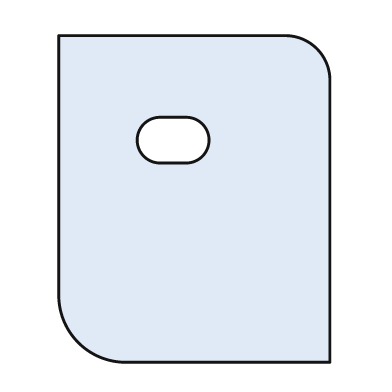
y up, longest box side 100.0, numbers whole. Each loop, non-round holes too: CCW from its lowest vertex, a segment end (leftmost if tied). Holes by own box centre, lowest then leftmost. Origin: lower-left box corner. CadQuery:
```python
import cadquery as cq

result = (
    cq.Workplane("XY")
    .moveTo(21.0, 0.0)
    .lineTo(83.0, 0.0)
    .lineTo(83.0, 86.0)
    .threePointArc((79.0, 96.0), (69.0, 100.0))
    .lineTo(0.0, 100.0)
    .lineTo(0.0, 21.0)
    .threePointArc((6.0, 6.0), (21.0, 0.0))
    .close()
    .moveTo(31.0, 61.0)
    .lineTo(39.0, 61.0)
    .threePointArc((46.0, 68.0), (39.0, 75.0))
    .lineTo(31.0, 75.0)
    .threePointArc((24.0, 68.0), (31.0, 61.0))
    .close()
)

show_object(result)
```